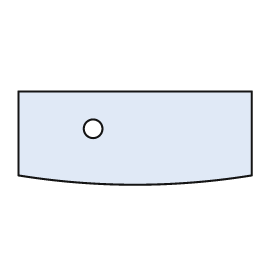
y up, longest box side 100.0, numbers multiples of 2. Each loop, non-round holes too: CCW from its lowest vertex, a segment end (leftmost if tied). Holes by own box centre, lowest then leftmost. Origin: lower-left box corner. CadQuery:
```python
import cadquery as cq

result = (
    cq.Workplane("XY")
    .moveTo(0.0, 4.0)
    .threePointArc((50.0, 0.0), (100.0, 4.0))
    .lineTo(100.0, 40.0)
    .lineTo(0.0, 40.0)
    .close()
    .moveTo(32.0, 24.0)
    .circle(4.0)
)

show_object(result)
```